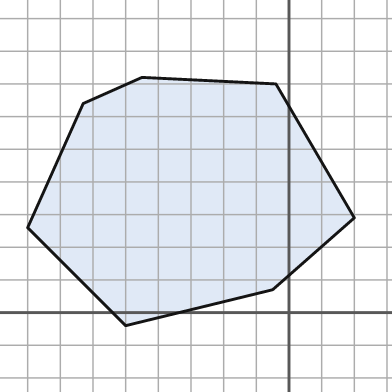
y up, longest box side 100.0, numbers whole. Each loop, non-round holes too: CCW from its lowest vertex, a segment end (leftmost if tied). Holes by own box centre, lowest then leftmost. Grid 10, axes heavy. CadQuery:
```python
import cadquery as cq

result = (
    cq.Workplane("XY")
    .moveTo(-50.0, -4.0)
    .lineTo(-5.0, 7.0)
    .lineTo(20.0, 29.0)
    .lineTo(-4.0, 70.0)
    .lineTo(-45.0, 72.0)
    .lineTo(-63.0, 64.0)
    .lineTo(-80.0, 26.0)
    .close()
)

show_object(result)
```